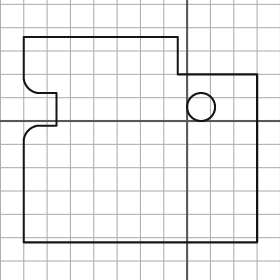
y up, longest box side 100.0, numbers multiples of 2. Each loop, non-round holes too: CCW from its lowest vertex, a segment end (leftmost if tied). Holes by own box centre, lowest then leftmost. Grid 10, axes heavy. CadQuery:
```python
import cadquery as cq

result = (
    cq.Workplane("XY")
    .moveTo(-70.0, -52.0)
    .lineTo(30.0, -52.0)
    .lineTo(30.0, 20.0)
    .lineTo(-4.0, 20.0)
    .lineTo(-4.0, 36.0)
    .lineTo(-70.0, 36.0)
    .lineTo(-70.0, 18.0)
    .threePointArc((-68.0, 14.0), (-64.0, 12.0))
    .lineTo(-56.0, 12.0)
    .lineTo(-56.0, -2.0)
    .lineTo(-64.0, -2.0)
    .threePointArc((-68.0, -4.0), (-70.0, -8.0))
    .close()
    .moveTo(6.0, 6.0)
    .circle(6.0)
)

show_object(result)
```